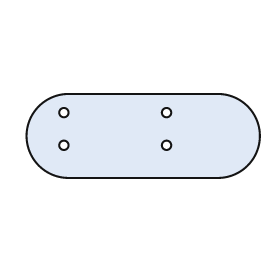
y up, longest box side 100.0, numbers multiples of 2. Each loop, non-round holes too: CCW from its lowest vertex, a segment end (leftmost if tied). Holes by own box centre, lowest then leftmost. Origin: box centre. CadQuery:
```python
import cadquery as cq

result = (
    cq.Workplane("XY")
    .moveTo(-32.0, -18.0)
    .lineTo(32.0, -18.0)
    .threePointArc((50.0, 0.0), (32.0, 18.0))
    .lineTo(-32.0, 18.0)
    .threePointArc((-50.0, 0.0), (-32.0, -18.0))
    .close()
    .moveTo(-34.0, -4.0)
    .circle(2.0)
    .moveTo(10.0, -4.0)
    .circle(2.0)
    .moveTo(-34.0, 10.0)
    .circle(2.0)
    .moveTo(10.0, 10.0)
    .circle(2.0)
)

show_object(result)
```